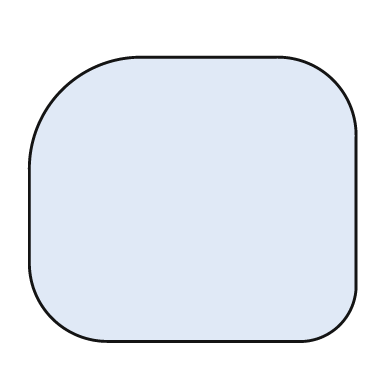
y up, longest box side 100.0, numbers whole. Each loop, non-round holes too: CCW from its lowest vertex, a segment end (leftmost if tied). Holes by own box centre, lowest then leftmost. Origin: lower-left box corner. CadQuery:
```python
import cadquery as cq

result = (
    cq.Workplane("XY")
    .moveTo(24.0, 0.0)
    .lineTo(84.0, 0.0)
    .threePointArc((95.0, 5.0), (100.0, 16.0))
    .lineTo(100.0, 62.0)
    .threePointArc((93.0, 80.0), (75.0, 87.0))
    .lineTo(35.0, 87.0)
    .threePointArc((10.0, 77.0), (0.0, 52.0))
    .lineTo(0.0, 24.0)
    .threePointArc((7.0, 7.0), (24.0, 0.0))
    .close()
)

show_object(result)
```